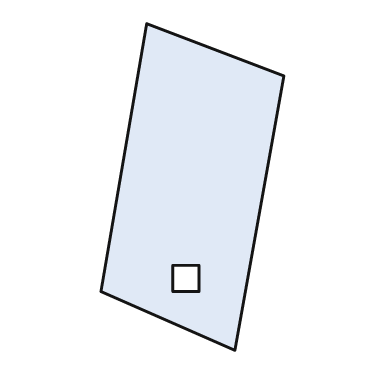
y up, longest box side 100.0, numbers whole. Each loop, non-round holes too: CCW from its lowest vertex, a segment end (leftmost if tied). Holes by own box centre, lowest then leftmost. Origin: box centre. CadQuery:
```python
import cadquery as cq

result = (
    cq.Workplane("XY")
    .moveTo(13.0, -50.0)
    .lineTo(28.0, 34.0)
    .lineTo(-14.0, 50.0)
    .lineTo(-28.0, -32.0)
    .close()
    .moveTo(-6.0, -32.0)
    .lineTo(2.0, -32.0)
    .lineTo(2.0, -24.0)
    .lineTo(-6.0, -24.0)
    .close()
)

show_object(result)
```